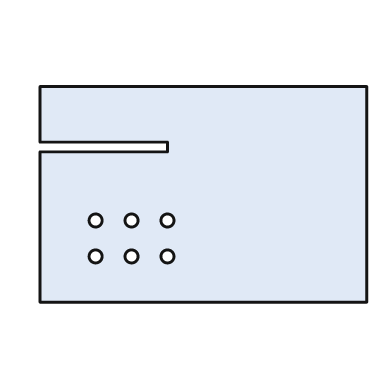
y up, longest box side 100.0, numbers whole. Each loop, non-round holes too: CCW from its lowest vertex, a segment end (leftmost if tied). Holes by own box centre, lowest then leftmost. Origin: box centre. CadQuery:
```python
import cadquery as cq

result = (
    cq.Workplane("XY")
    .moveTo(-50.0, -33.0)
    .lineTo(50.0, -33.0)
    .lineTo(50.0, 33.0)
    .lineTo(-50.0, 33.0)
    .lineTo(-50.0, 16.0)
    .lineTo(-11.0, 16.0)
    .lineTo(-11.0, 13.0)
    .lineTo(-50.0, 13.0)
    .close()
    .moveTo(-33.0, -19.0)
    .circle(2.0)
    .moveTo(-22.0, -19.0)
    .circle(2.0)
    .moveTo(-11.0, -19.0)
    .circle(2.0)
    .moveTo(-33.0, -8.0)
    .circle(2.0)
    .moveTo(-22.0, -8.0)
    .circle(2.0)
    .moveTo(-11.0, -8.0)
    .circle(2.0)
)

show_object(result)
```